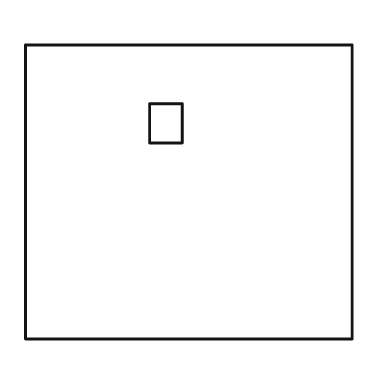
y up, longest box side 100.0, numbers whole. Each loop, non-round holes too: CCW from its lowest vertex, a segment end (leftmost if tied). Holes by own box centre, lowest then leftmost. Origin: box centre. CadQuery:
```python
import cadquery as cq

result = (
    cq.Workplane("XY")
    .moveTo(-50.0, -45.0)
    .lineTo(50.0, -45.0)
    .lineTo(50.0, 45.0)
    .lineTo(-50.0, 45.0)
    .close()
    .moveTo(-12.0, 15.0)
    .lineTo(-2.0, 15.0)
    .lineTo(-2.0, 27.0)
    .lineTo(-12.0, 27.0)
    .close()
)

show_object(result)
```